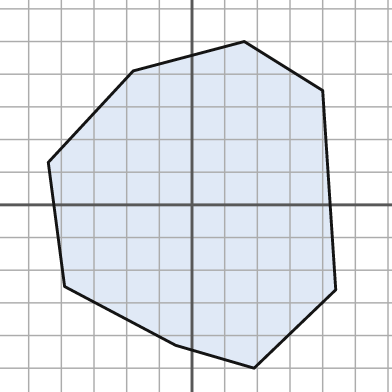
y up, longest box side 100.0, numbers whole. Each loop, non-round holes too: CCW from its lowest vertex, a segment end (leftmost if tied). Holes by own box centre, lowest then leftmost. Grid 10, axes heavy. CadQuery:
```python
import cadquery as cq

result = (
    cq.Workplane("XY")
    .moveTo(19.0, -50.0)
    .lineTo(44.0, -26.0)
    .lineTo(40.0, 35.0)
    .lineTo(16.0, 50.0)
    .lineTo(-18.0, 41.0)
    .lineTo(-44.0, 13.0)
    .lineTo(-39.0, -25.0)
    .lineTo(-5.0, -43.0)
    .close()
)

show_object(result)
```